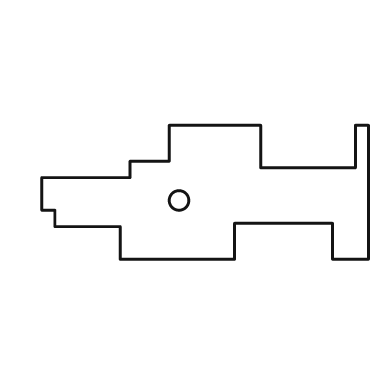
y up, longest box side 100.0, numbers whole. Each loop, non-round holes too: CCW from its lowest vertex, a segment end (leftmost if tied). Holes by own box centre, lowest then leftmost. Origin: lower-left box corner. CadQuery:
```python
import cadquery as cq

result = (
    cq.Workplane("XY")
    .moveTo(24.0, 0.0)
    .lineTo(59.0, 0.0)
    .lineTo(59.0, 11.0)
    .lineTo(89.0, 11.0)
    .lineTo(89.0, 0.0)
    .lineTo(100.0, 0.0)
    .lineTo(100.0, 41.0)
    .lineTo(96.0, 41.0)
    .lineTo(96.0, 28.0)
    .lineTo(67.0, 28.0)
    .lineTo(67.0, 41.0)
    .lineTo(39.0, 41.0)
    .lineTo(39.0, 30.0)
    .lineTo(27.0, 30.0)
    .lineTo(27.0, 25.0)
    .lineTo(0.0, 25.0)
    .lineTo(0.0, 15.0)
    .lineTo(4.0, 15.0)
    .lineTo(4.0, 10.0)
    .lineTo(24.0, 10.0)
    .close()
    .moveTo(42.0, 18.0)
    .circle(3.0)
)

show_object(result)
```